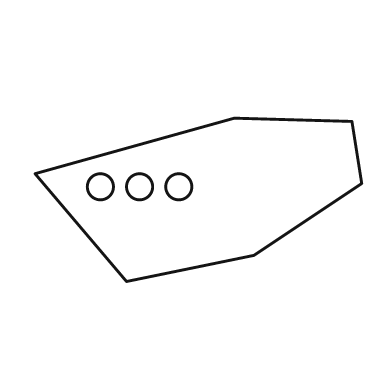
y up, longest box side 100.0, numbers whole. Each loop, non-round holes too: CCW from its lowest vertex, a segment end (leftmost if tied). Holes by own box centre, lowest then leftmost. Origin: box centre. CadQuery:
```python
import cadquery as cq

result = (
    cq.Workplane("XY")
    .moveTo(-22.0, -25.0)
    .lineTo(17.0, -17.0)
    .lineTo(50.0, 5.0)
    .lineTo(47.0, 24.0)
    .lineTo(11.0, 25.0)
    .lineTo(-50.0, 8.0)
    .close()
    .moveTo(-30.0, 4.0)
    .circle(4.0)
    .moveTo(-18.0, 4.0)
    .circle(4.0)
    .moveTo(-6.0, 4.0)
    .circle(4.0)
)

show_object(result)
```